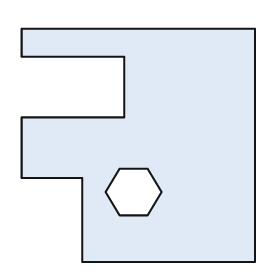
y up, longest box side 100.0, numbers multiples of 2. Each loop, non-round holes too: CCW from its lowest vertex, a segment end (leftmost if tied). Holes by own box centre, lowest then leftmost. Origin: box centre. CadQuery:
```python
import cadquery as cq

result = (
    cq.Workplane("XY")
    .moveTo(-24.0, -50.0)
    .lineTo(50.0, -50.0)
    .lineTo(50.0, 50.0)
    .lineTo(-50.0, 50.0)
    .lineTo(-50.0, 38.0)
    .lineTo(-6.0, 38.0)
    .lineTo(-6.0, 12.0)
    .lineTo(-50.0, 12.0)
    .lineTo(-50.0, -14.0)
    .lineTo(-24.0, -14.0)
    .close()
    .moveTo(-8.0, -30.0)
    .lineTo(4.0, -30.0)
    .lineTo(10.0, -20.0)
    .lineTo(4.0, -10.0)
    .lineTo(-8.0, -10.0)
    .lineTo(-14.0, -20.0)
    .close()
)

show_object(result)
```